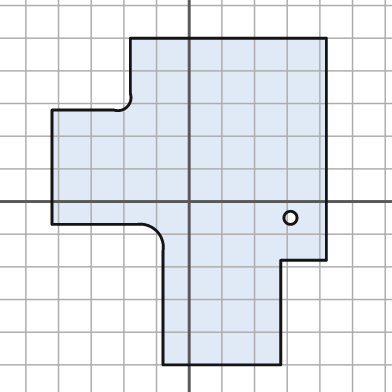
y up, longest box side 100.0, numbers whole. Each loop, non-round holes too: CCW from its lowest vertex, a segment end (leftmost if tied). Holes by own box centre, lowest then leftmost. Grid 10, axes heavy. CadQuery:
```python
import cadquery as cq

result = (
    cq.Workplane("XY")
    .moveTo(-8.0, -50.0)
    .lineTo(28.0, -50.0)
    .lineTo(28.0, -18.0)
    .lineTo(42.0, -18.0)
    .lineTo(42.0, 50.0)
    .lineTo(-18.0, 50.0)
    .lineTo(-18.0, 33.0)
    .threePointArc((-19.0, 29.0), (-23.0, 28.0))
    .lineTo(-42.0, 28.0)
    .lineTo(-42.0, -7.0)
    .lineTo(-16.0, -7.0)
    .threePointArc((-10.0, -9.0), (-8.0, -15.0))
    .close()
    .moveTo(31.0, -5.0)
    .circle(2.0)
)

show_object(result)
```